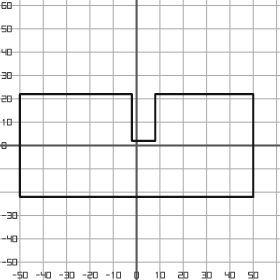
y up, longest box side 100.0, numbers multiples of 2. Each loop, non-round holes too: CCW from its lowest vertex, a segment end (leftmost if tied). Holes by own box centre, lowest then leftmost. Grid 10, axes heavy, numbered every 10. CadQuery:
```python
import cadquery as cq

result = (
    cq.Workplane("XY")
    .moveTo(-50.0, -22.0)
    .lineTo(50.0, -22.0)
    .lineTo(50.0, 22.0)
    .lineTo(8.0, 22.0)
    .lineTo(8.0, 2.0)
    .lineTo(-2.0, 2.0)
    .lineTo(-2.0, 22.0)
    .lineTo(-50.0, 22.0)
    .close()
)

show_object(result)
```